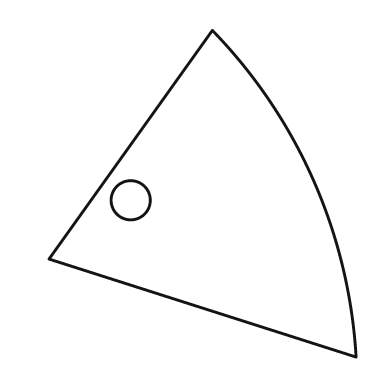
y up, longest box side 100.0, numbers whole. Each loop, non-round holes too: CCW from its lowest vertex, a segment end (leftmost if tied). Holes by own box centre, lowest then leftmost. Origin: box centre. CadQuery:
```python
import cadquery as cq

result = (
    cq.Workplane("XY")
    .moveTo(47.0, -50.0)
    .threePointArc((34.0, 4.0), (3.0, 50.0))
    .lineTo(-47.0, -20.0)
    .close()
    .moveTo(-22.0, -2.0)
    .circle(6.0)
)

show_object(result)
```